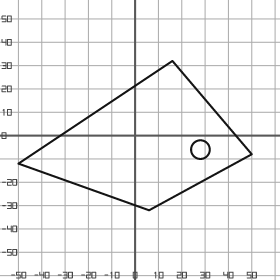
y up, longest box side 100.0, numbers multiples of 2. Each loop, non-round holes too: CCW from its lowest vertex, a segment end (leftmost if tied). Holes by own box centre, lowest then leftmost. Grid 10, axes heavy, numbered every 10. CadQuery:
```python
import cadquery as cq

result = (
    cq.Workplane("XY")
    .moveTo(6.0, -32.0)
    .lineTo(50.0, -8.0)
    .lineTo(16.0, 32.0)
    .lineTo(-50.0, -12.0)
    .close()
    .moveTo(28.0, -6.0)
    .circle(4.0)
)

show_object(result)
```